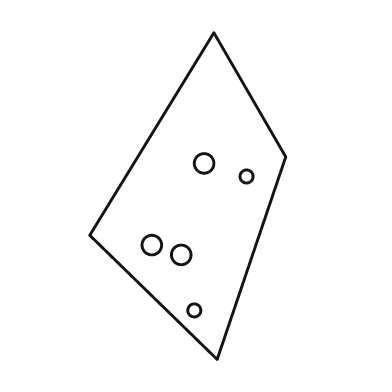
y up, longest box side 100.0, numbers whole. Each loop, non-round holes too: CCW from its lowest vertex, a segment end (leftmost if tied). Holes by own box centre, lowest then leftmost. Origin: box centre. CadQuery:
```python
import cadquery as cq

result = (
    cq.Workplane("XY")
    .moveTo(9.0, -50.0)
    .lineTo(30.0, 12.0)
    .lineTo(8.0, 50.0)
    .lineTo(-30.0, -12.0)
    .close()
    .moveTo(2.0, -35.0)
    .circle(2.0)
    .moveTo(-2.0, -18.0)
    .circle(3.0)
    .moveTo(-11.0, -15.0)
    .circle(3.0)
    .moveTo(18.0, 6.0)
    .circle(2.0)
    .moveTo(5.0, 10.0)
    .circle(3.0)
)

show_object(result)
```